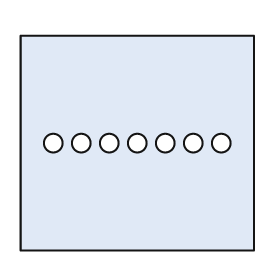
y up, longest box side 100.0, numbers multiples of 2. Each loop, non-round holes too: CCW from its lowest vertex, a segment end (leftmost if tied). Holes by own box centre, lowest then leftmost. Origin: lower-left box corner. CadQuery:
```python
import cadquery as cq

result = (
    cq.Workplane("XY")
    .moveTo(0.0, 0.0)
    .lineTo(100.0, 0.0)
    .lineTo(100.0, 92.0)
    .lineTo(0.0, 92.0)
    .close()
    .moveTo(14.0, 46.0)
    .circle(4.0)
    .moveTo(26.0, 46.0)
    .circle(4.0)
    .moveTo(38.0, 46.0)
    .circle(4.0)
    .moveTo(50.0, 46.0)
    .circle(4.0)
    .moveTo(62.0, 46.0)
    .circle(4.0)
    .moveTo(74.0, 46.0)
    .circle(4.0)
    .moveTo(86.0, 46.0)
    .circle(4.0)
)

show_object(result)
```